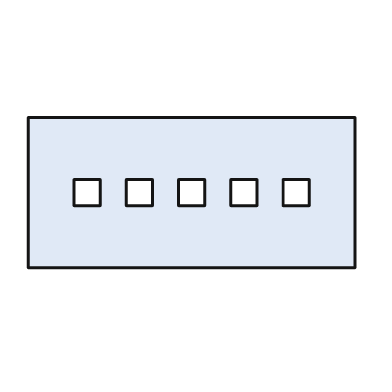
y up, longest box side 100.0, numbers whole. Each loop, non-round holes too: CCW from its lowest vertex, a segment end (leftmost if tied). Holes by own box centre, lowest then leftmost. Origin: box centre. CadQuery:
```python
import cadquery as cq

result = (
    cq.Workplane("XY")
    .moveTo(-50.0, -23.0)
    .lineTo(50.0, -23.0)
    .lineTo(50.0, 23.0)
    .lineTo(-50.0, 23.0)
    .close()
    .moveTo(-36.0, -4.0)
    .lineTo(-28.0, -4.0)
    .lineTo(-28.0, 4.0)
    .lineTo(-36.0, 4.0)
    .close()
    .moveTo(-20.0, -4.0)
    .lineTo(-12.0, -4.0)
    .lineTo(-12.0, 4.0)
    .lineTo(-20.0, 4.0)
    .close()
    .moveTo(-4.0, -4.0)
    .lineTo(4.0, -4.0)
    .lineTo(4.0, 4.0)
    .lineTo(-4.0, 4.0)
    .close()
    .moveTo(12.0, -4.0)
    .lineTo(20.0, -4.0)
    .lineTo(20.0, 4.0)
    .lineTo(12.0, 4.0)
    .close()
    .moveTo(28.0, -4.0)
    .lineTo(36.0, -4.0)
    .lineTo(36.0, 4.0)
    .lineTo(28.0, 4.0)
    .close()
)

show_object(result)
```